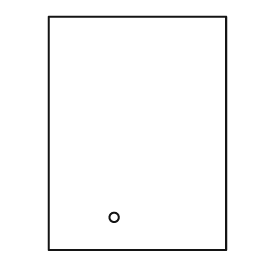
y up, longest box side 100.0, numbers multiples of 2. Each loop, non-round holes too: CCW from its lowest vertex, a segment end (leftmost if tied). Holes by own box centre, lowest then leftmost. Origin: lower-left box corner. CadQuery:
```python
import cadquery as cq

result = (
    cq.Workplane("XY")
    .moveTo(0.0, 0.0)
    .lineTo(76.0, 0.0)
    .lineTo(76.0, 100.0)
    .lineTo(0.0, 100.0)
    .close()
    .moveTo(28.0, 14.0)
    .circle(2.0)
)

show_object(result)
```